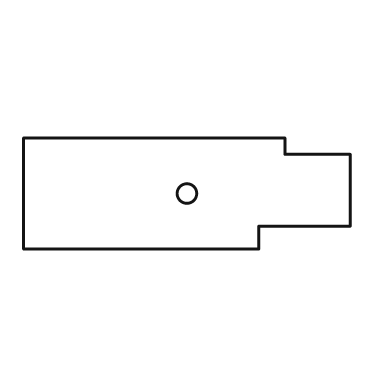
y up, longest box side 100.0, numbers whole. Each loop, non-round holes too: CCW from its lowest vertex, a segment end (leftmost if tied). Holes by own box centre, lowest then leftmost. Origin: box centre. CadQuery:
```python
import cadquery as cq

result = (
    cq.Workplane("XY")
    .moveTo(-50.0, -17.0)
    .lineTo(22.0, -17.0)
    .lineTo(22.0, -10.0)
    .lineTo(50.0, -10.0)
    .lineTo(50.0, 12.0)
    .lineTo(30.0, 12.0)
    .lineTo(30.0, 17.0)
    .lineTo(-50.0, 17.0)
    .close()
    .moveTo(0.0, 0.0)
    .circle(3.0)
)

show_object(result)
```